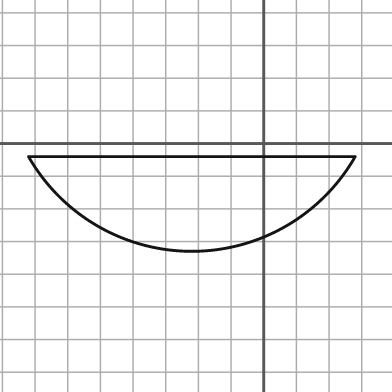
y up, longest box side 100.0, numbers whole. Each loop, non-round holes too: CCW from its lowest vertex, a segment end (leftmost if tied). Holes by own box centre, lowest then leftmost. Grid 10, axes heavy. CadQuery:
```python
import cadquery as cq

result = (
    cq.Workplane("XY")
    .moveTo(-72.0, -4.0)
    .threePointArc((-22.0, -33.0), (28.0, -4.0))
    .close()
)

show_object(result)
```